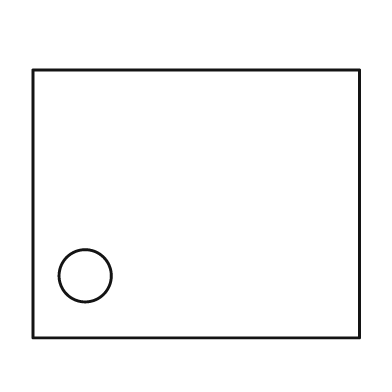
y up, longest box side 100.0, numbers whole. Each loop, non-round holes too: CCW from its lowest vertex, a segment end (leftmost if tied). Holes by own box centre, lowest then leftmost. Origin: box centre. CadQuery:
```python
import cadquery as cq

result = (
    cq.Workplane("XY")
    .moveTo(-50.0, -41.0)
    .lineTo(50.0, -41.0)
    .lineTo(50.0, 41.0)
    .lineTo(-50.0, 41.0)
    .close()
    .moveTo(-34.0, -22.0)
    .circle(8.0)
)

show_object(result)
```